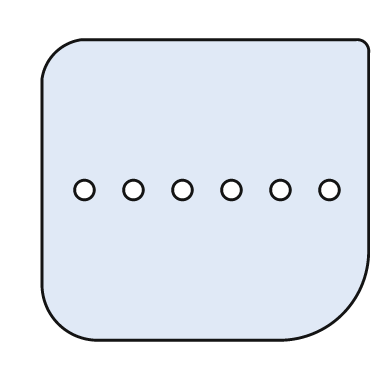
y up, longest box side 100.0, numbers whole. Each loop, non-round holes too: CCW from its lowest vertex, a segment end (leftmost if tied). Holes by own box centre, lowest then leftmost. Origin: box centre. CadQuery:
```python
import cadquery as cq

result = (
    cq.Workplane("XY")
    .moveTo(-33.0, -46.0)
    .lineTo(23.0, -46.0)
    .threePointArc((42.0, -38.0), (50.0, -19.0))
    .lineTo(50.0, 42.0)
    .threePointArc((49.0, 45.0), (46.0, 46.0))
    .lineTo(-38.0, 46.0)
    .threePointArc((-46.0, 42.0), (-50.0, 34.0))
    .lineTo(-50.0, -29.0)
    .threePointArc((-45.0, -41.0), (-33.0, -46.0))
    .close()
    .moveTo(-37.0, 0.0)
    .circle(3.0)
    .moveTo(-22.0, 0.0)
    .circle(3.0)
    .moveTo(-7.0, 0.0)
    .circle(3.0)
    .moveTo(8.0, 0.0)
    .circle(3.0)
    .moveTo(23.0, 0.0)
    .circle(3.0)
    .moveTo(38.0, 0.0)
    .circle(3.0)
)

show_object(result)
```